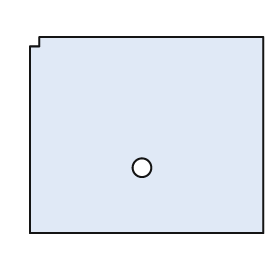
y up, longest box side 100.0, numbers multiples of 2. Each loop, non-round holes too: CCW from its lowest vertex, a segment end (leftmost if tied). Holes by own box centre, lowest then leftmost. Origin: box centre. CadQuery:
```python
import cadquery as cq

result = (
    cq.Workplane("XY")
    .moveTo(-50.0, -42.0)
    .lineTo(50.0, -42.0)
    .lineTo(50.0, 42.0)
    .lineTo(-46.0, 42.0)
    .lineTo(-46.0, 38.0)
    .lineTo(-50.0, 38.0)
    .close()
    .moveTo(-2.0, -14.0)
    .circle(4.0)
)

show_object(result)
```